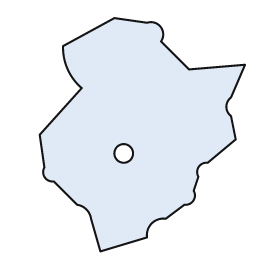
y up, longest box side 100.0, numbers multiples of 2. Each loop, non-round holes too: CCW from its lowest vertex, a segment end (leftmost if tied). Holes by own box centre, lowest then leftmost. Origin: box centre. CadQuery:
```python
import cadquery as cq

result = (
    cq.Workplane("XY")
    .moveTo(-18.0, -50.0)
    .lineTo(2.0, -44.0)
    .threePointArc((4.0, -38.0), (10.0, -36.0))
    .lineTo(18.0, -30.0)
    .threePointArc((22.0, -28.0), (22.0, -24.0))
    .lineTo(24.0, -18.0)
    .threePointArc((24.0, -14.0), (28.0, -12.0))
    .lineTo(40.0, -2.0)
    .lineTo(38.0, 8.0)
    .threePointArc((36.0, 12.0), (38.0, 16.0))
    .lineTo(44.0, 30.0)
    .lineTo(20.0, 28.0)
    .lineTo(8.0, 40.0)
    .threePointArc((8.0, 46.0), (2.0, 48.0))
    .lineTo(-12.0, 50.0)
    .lineTo(-34.0, 38.0)
    .threePointArc((-32.0, 28.0), (-26.0, 20.0))
    .lineTo(-44.0, 0.0)
    .lineTo(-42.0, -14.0)
    .threePointArc((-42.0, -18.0), (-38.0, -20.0))
    .lineTo(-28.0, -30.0)
    .threePointArc((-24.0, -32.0), (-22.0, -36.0))
    .close()
    .moveTo(-8.0, -8.0)
    .circle(4.0)
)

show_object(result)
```